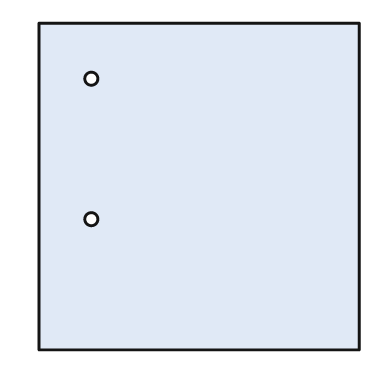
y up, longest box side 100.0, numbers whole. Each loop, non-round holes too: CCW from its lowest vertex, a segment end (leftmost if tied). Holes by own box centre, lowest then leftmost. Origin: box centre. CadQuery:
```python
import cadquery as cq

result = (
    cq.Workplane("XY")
    .moveTo(-49.0, -50.0)
    .lineTo(49.0, -50.0)
    .lineTo(49.0, 50.0)
    .lineTo(-49.0, 50.0)
    .close()
    .moveTo(-33.0, -10.0)
    .circle(2.0)
    .moveTo(-33.0, 33.0)
    .circle(2.0)
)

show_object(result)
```